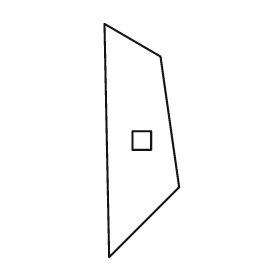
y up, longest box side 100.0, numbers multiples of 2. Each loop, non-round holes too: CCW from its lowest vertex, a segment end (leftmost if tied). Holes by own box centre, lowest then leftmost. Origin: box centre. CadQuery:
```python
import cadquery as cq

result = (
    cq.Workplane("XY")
    .moveTo(-14.0, -50.0)
    .lineTo(16.0, -20.0)
    .lineTo(8.0, 36.0)
    .lineTo(-16.0, 50.0)
    .close()
    .moveTo(-4.0, -4.0)
    .lineTo(4.0, -4.0)
    .lineTo(4.0, 4.0)
    .lineTo(-4.0, 4.0)
    .close()
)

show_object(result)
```